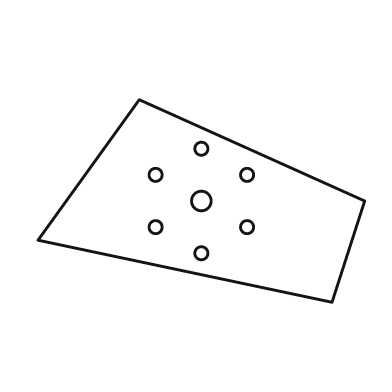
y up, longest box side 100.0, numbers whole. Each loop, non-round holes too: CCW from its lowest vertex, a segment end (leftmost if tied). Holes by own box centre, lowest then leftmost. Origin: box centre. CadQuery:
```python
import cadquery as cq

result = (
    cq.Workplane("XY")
    .moveTo(40.0, -31.0)
    .lineTo(50.0, 0.0)
    .lineTo(-19.0, 31.0)
    .lineTo(-50.0, -12.0)
    .close()
    .moveTo(0.0, -16.0)
    .circle(2.0)
    .moveTo(-14.0, -8.0)
    .circle(2.0)
    .moveTo(14.0, -8.0)
    .circle(2.0)
    .moveTo(0.0, 0.0)
    .circle(3.0)
    .moveTo(-14.0, 8.0)
    .circle(2.0)
    .moveTo(14.0, 8.0)
    .circle(2.0)
    .moveTo(0.0, 16.0)
    .circle(2.0)
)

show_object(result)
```